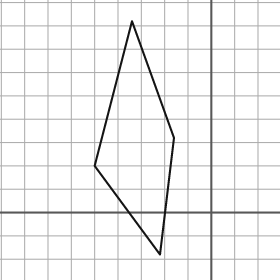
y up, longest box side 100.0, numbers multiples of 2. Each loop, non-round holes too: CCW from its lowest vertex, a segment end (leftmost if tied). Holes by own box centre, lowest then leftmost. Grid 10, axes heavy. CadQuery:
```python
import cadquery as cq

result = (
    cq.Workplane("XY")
    .moveTo(-22.0, -18.0)
    .lineTo(-16.0, 32.0)
    .lineTo(-34.0, 82.0)
    .lineTo(-50.0, 20.0)
    .close()
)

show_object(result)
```